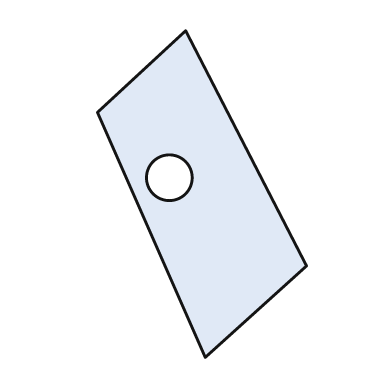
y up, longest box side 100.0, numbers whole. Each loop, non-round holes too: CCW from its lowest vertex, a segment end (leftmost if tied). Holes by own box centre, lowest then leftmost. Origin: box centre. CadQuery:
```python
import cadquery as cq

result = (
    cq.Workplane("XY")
    .moveTo(1.0, -50.0)
    .lineTo(32.0, -22.0)
    .lineTo(-5.0, 50.0)
    .lineTo(-32.0, 25.0)
    .close()
    .moveTo(-10.0, 5.0)
    .circle(7.0)
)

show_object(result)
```